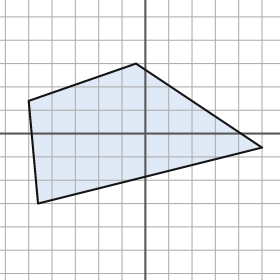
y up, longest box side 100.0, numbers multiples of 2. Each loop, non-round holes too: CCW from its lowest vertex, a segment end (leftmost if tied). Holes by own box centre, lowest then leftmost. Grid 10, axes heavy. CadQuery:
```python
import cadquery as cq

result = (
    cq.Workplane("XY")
    .moveTo(-46.0, -30.0)
    .lineTo(50.0, -6.0)
    .lineTo(-4.0, 30.0)
    .lineTo(-50.0, 14.0)
    .close()
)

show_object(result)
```